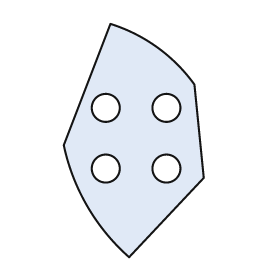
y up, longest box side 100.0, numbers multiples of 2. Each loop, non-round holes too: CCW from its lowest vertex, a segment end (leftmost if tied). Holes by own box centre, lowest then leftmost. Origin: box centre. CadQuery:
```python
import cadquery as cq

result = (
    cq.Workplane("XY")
    .moveTo(-2.0, -50.0)
    .lineTo(30.0, -16.0)
    .lineTo(26.0, 24.0)
    .threePointArc((10.0, 40.0), (-10.0, 50.0))
    .lineTo(-30.0, -2.0)
    .threePointArc((-20.0, -28.0), (-2.0, -50.0))
    .close()
    .moveTo(-12.0, -12.0)
    .circle(6.0)
    .moveTo(14.0, -12.0)
    .circle(6.0)
    .moveTo(-12.0, 14.0)
    .circle(6.0)
    .moveTo(14.0, 14.0)
    .circle(6.0)
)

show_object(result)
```